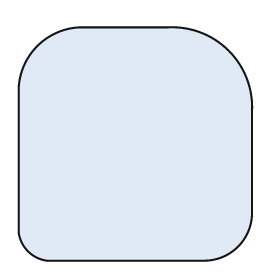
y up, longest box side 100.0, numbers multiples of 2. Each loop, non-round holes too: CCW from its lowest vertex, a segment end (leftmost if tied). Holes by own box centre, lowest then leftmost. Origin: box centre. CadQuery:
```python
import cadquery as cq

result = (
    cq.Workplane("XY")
    .moveTo(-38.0, -50.0)
    .lineTo(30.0, -50.0)
    .threePointArc((44.0, -44.0), (50.0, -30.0))
    .lineTo(50.0, 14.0)
    .threePointArc((40.0, 40.0), (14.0, 50.0))
    .lineTo(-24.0, 50.0)
    .threePointArc((-42.0, 42.0), (-50.0, 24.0))
    .lineTo(-50.0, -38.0)
    .threePointArc((-46.0, -46.0), (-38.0, -50.0))
    .close()
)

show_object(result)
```